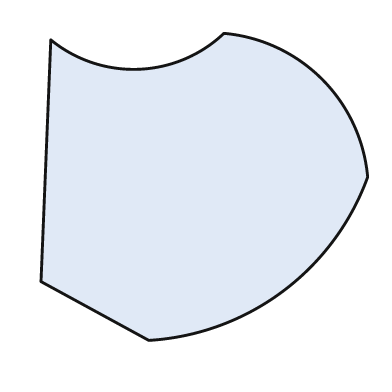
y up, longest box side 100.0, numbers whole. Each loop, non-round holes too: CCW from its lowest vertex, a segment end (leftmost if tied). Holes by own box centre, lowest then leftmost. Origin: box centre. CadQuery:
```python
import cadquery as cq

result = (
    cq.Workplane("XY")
    .moveTo(-17.0, -47.0)
    .threePointArc((24.0, -32.0), (50.0, 3.0))
    .threePointArc((36.0, 33.0), (6.0, 47.0))
    .threePointArc((-20.0, 36.0), (-47.0, 45.0))
    .lineTo(-50.0, -29.0)
    .close()
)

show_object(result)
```